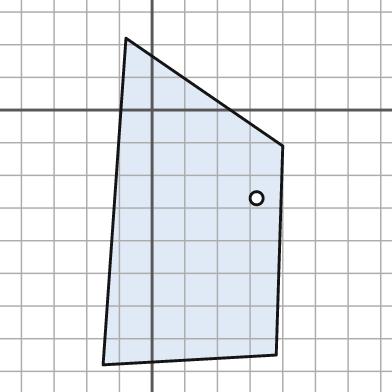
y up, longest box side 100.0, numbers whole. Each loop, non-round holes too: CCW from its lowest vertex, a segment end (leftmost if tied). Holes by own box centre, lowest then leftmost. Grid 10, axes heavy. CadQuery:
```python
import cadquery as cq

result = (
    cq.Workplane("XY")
    .moveTo(-15.0, -78.0)
    .lineTo(38.0, -75.0)
    .lineTo(40.0, -11.0)
    .lineTo(-8.0, 22.0)
    .close()
    .moveTo(32.0, -27.0)
    .circle(2.0)
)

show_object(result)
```